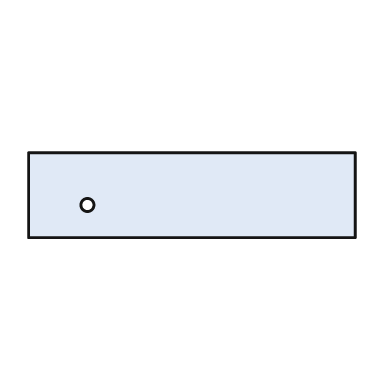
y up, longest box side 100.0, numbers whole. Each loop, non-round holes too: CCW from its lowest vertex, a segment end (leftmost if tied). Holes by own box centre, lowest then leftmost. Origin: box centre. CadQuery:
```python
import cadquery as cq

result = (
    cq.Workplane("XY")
    .moveTo(-50.0, -13.0)
    .lineTo(50.0, -13.0)
    .lineTo(50.0, 13.0)
    .lineTo(-50.0, 13.0)
    .close()
    .moveTo(-32.0, -3.0)
    .circle(2.0)
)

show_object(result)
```